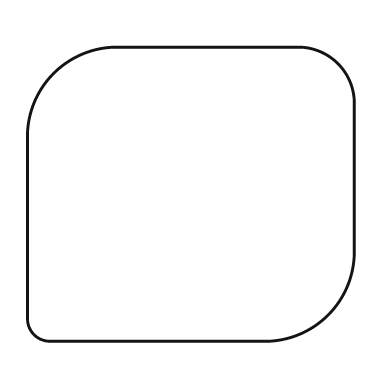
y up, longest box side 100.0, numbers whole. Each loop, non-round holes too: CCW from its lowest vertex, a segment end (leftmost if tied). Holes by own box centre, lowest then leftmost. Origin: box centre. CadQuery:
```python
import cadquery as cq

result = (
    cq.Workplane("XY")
    .moveTo(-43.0, -45.0)
    .lineTo(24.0, -45.0)
    .threePointArc((42.0, -37.0), (50.0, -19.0))
    .lineTo(50.0, 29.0)
    .threePointArc((45.0, 40.0), (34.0, 45.0))
    .lineTo(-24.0, 45.0)
    .threePointArc((-42.0, 37.0), (-50.0, 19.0))
    .lineTo(-50.0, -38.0)
    .threePointArc((-48.0, -43.0), (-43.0, -45.0))
    .close()
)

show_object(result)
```